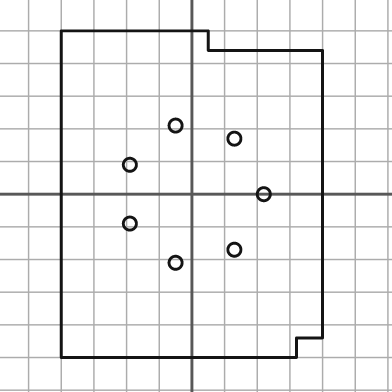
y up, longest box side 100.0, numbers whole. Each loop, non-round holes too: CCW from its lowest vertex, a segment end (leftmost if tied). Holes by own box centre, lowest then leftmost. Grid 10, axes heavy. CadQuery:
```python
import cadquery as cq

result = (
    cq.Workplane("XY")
    .moveTo(-40.0, -50.0)
    .lineTo(32.0, -50.0)
    .lineTo(32.0, -44.0)
    .lineTo(40.0, -44.0)
    .lineTo(40.0, 44.0)
    .lineTo(5.0, 44.0)
    .lineTo(5.0, 50.0)
    .lineTo(-40.0, 50.0)
    .close()
    .moveTo(-5.0, -21.0)
    .circle(2.0)
    .moveTo(13.0, -17.0)
    .circle(2.0)
    .moveTo(-19.0, -9.0)
    .circle(2.0)
    .moveTo(22.0, 0.0)
    .circle(2.0)
    .moveTo(-19.0, 9.0)
    .circle(2.0)
    .moveTo(13.0, 17.0)
    .circle(2.0)
    .moveTo(-5.0, 21.0)
    .circle(2.0)
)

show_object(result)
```